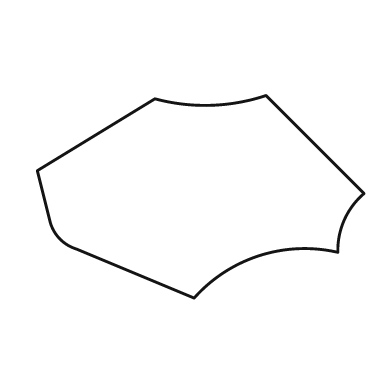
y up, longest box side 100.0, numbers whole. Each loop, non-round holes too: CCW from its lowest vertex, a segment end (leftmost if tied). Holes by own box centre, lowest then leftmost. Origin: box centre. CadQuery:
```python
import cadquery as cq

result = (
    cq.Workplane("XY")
    .moveTo(-2.0, -31.0)
    .threePointArc((18.0, -18.0), (42.0, -17.0))
    .threePointArc((44.0, -7.0), (50.0, 1.0))
    .lineTo(20.0, 31.0)
    .threePointArc((3.0, 28.0), (-14.0, 30.0))
    .lineTo(-50.0, 8.0)
    .lineTo(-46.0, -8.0)
    .threePointArc((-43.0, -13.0), (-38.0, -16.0))
    .close()
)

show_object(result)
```